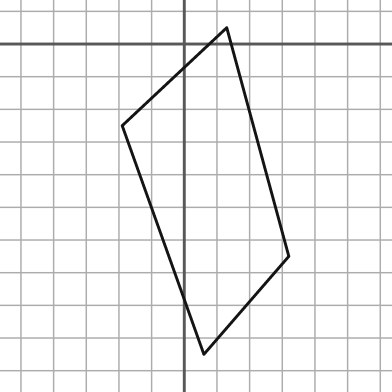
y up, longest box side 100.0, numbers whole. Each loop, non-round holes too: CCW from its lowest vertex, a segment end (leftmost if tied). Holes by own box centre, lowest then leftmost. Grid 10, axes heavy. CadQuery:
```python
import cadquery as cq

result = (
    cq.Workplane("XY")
    .moveTo(6.0, -95.0)
    .lineTo(32.0, -65.0)
    .lineTo(13.0, 5.0)
    .lineTo(-19.0, -25.0)
    .close()
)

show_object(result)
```